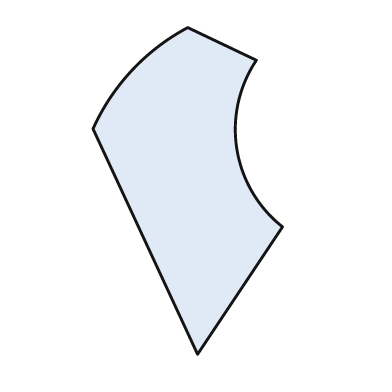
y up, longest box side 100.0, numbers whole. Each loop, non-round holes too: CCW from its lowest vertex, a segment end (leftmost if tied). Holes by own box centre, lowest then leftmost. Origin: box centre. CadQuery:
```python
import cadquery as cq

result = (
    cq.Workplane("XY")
    .moveTo(3.0, -50.0)
    .lineTo(29.0, -11.0)
    .threePointArc((15.0, 13.0), (21.0, 40.0))
    .lineTo(0.0, 50.0)
    .threePointArc((-17.0, 37.0), (-29.0, 19.0))
    .close()
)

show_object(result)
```